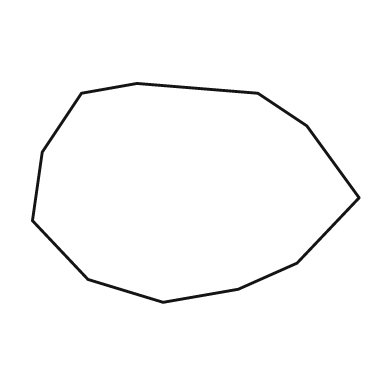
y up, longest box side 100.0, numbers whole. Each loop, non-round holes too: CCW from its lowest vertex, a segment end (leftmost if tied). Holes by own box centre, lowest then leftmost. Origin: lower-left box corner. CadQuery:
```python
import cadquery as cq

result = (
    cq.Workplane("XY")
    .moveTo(40.0, 0.0)
    .lineTo(63.0, 4.0)
    .lineTo(81.0, 12.0)
    .lineTo(100.0, 32.0)
    .lineTo(84.0, 54.0)
    .lineTo(69.0, 64.0)
    .lineTo(32.0, 67.0)
    .lineTo(15.0, 64.0)
    .lineTo(3.0, 46.0)
    .lineTo(0.0, 25.0)
    .lineTo(17.0, 7.0)
    .close()
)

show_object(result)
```